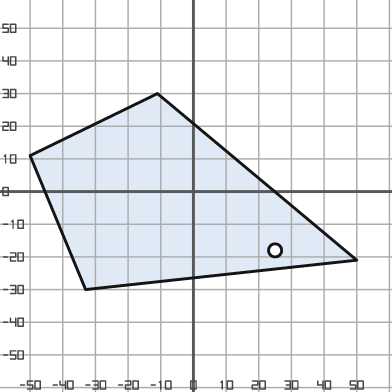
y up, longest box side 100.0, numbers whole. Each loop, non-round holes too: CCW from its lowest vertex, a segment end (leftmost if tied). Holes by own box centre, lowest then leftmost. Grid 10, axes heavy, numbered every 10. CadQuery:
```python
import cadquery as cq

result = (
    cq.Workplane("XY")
    .moveTo(-33.0, -30.0)
    .lineTo(50.0, -21.0)
    .lineTo(-11.0, 30.0)
    .lineTo(-50.0, 11.0)
    .close()
    .moveTo(25.0, -18.0)
    .circle(2.0)
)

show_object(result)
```